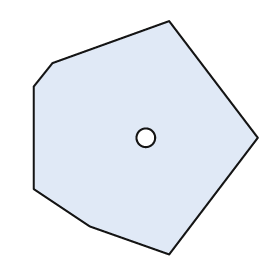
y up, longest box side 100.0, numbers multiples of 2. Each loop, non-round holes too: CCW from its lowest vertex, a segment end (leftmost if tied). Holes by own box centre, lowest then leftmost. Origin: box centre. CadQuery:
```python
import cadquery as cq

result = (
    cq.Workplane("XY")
    .moveTo(10.0, -50.0)
    .lineTo(48.0, 0.0)
    .lineTo(10.0, 50.0)
    .lineTo(-40.0, 32.0)
    .lineTo(-48.0, 22.0)
    .lineTo(-48.0, -22.0)
    .lineTo(-24.0, -38.0)
    .close()
    .moveTo(0.0, 0.0)
    .circle(4.0)
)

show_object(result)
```